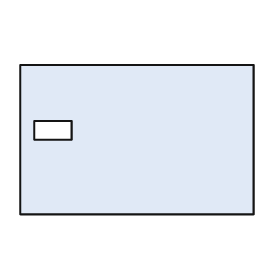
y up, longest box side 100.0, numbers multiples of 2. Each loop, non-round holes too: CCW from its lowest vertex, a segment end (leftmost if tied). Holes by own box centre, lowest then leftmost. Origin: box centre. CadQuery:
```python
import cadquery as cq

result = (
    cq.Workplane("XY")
    .moveTo(-50.0, -32.0)
    .lineTo(50.0, -32.0)
    .lineTo(50.0, 32.0)
    .lineTo(-50.0, 32.0)
    .close()
    .moveTo(-44.0, 0.0)
    .lineTo(-28.0, 0.0)
    .lineTo(-28.0, 8.0)
    .lineTo(-44.0, 8.0)
    .close()
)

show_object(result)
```